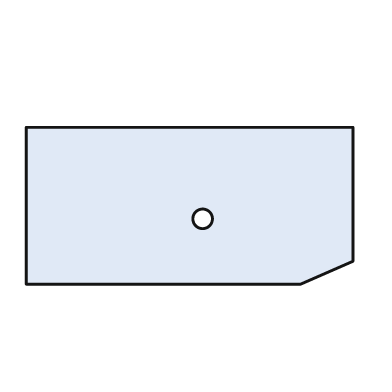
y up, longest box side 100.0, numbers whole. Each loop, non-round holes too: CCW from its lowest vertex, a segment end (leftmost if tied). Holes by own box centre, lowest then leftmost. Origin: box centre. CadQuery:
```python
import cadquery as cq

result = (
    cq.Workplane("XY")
    .moveTo(-50.0, -24.0)
    .lineTo(34.0, -24.0)
    .lineTo(50.0, -17.0)
    .lineTo(50.0, 24.0)
    .lineTo(-50.0, 24.0)
    .close()
    .moveTo(4.0, -4.0)
    .circle(3.0)
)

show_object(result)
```